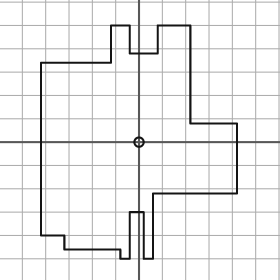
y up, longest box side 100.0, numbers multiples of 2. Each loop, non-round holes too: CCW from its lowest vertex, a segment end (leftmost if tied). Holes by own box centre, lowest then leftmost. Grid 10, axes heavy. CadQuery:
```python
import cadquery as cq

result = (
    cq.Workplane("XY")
    .moveTo(-8.0, -50.0)
    .lineTo(-4.0, -50.0)
    .lineTo(-4.0, -30.0)
    .lineTo(2.0, -30.0)
    .lineTo(2.0, -50.0)
    .lineTo(6.0, -50.0)
    .lineTo(6.0, -22.0)
    .lineTo(42.0, -22.0)
    .lineTo(42.0, 8.0)
    .lineTo(22.0, 8.0)
    .lineTo(22.0, 50.0)
    .lineTo(8.0, 50.0)
    .lineTo(8.0, 38.0)
    .lineTo(-4.0, 38.0)
    .lineTo(-4.0, 50.0)
    .lineTo(-12.0, 50.0)
    .lineTo(-12.0, 34.0)
    .lineTo(-42.0, 34.0)
    .lineTo(-42.0, -40.0)
    .lineTo(-32.0, -40.0)
    .lineTo(-32.0, -46.0)
    .lineTo(-8.0, -46.0)
    .close()
    .moveTo(0.0, 0.0)
    .circle(2.0)
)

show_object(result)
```